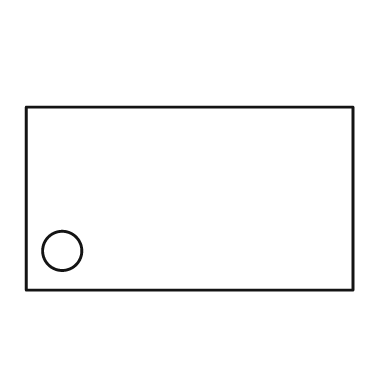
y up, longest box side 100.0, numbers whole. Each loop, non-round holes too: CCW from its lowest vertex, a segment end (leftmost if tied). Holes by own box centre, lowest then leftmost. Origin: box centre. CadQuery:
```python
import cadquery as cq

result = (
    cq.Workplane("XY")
    .moveTo(-50.0, -28.0)
    .lineTo(50.0, -28.0)
    .lineTo(50.0, 28.0)
    .lineTo(-50.0, 28.0)
    .close()
    .moveTo(-39.0, -16.0)
    .circle(6.0)
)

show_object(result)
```